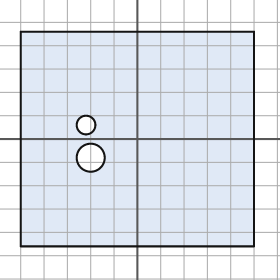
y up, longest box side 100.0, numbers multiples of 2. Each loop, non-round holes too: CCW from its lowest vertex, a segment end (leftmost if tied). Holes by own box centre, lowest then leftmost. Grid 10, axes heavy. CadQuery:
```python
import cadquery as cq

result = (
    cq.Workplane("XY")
    .moveTo(-50.0, -46.0)
    .lineTo(50.0, -46.0)
    .lineTo(50.0, 46.0)
    .lineTo(-50.0, 46.0)
    .close()
    .moveTo(-20.0, -8.0)
    .circle(6.0)
    .moveTo(-22.0, 6.0)
    .circle(4.0)
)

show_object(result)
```